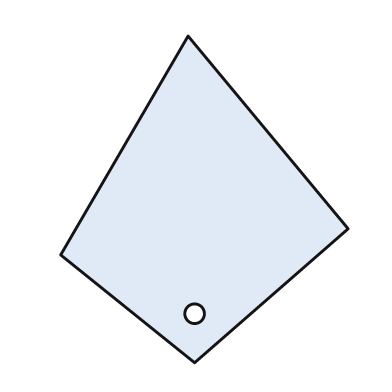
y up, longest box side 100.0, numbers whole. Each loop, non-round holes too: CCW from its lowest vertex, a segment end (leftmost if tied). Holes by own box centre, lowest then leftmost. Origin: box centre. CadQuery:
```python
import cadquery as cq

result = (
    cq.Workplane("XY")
    .moveTo(-3.0, -50.0)
    .lineTo(44.0, -9.0)
    .lineTo(-5.0, 50.0)
    .lineTo(-44.0, -17.0)
    .close()
    .moveTo(-3.0, -35.0)
    .circle(3.0)
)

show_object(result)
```